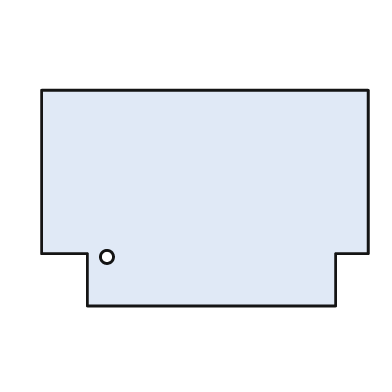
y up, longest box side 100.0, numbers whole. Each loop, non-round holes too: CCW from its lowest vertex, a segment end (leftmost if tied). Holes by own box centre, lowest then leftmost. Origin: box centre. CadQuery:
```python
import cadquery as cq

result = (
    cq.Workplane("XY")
    .moveTo(-36.0, -33.0)
    .lineTo(40.0, -33.0)
    .lineTo(40.0, -17.0)
    .lineTo(50.0, -17.0)
    .lineTo(50.0, 33.0)
    .lineTo(-50.0, 33.0)
    .lineTo(-50.0, -17.0)
    .lineTo(-36.0, -17.0)
    .close()
    .moveTo(-30.0, -18.0)
    .circle(2.0)
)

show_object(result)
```